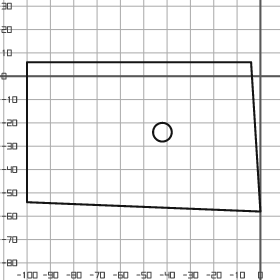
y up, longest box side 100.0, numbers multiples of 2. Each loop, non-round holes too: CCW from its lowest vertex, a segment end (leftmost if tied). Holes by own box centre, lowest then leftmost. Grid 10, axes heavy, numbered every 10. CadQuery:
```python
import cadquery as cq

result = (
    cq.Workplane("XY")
    .moveTo(0.0, -58.0)
    .lineTo(-4.0, 6.0)
    .lineTo(-100.0, 6.0)
    .lineTo(-100.0, -54.0)
    .close()
    .moveTo(-42.0, -24.0)
    .circle(4.0)
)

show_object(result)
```